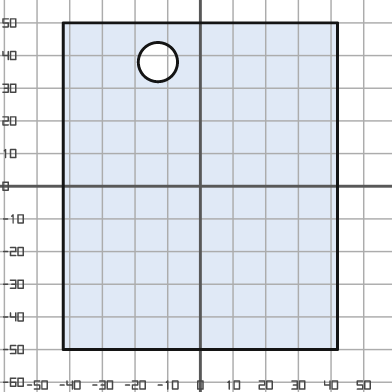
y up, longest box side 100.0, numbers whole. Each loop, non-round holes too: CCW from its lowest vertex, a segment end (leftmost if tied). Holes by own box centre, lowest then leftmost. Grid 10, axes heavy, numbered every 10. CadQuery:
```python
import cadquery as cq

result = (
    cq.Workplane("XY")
    .moveTo(-42.0, -50.0)
    .lineTo(42.0, -50.0)
    .lineTo(42.0, 50.0)
    .lineTo(-42.0, 50.0)
    .close()
    .moveTo(-13.0, 38.0)
    .circle(6.0)
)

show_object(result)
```